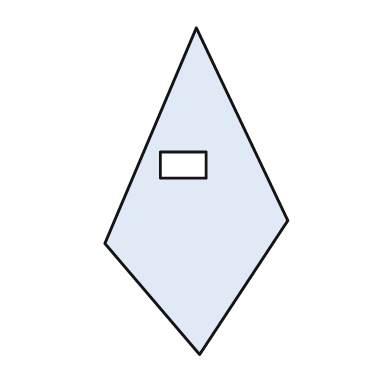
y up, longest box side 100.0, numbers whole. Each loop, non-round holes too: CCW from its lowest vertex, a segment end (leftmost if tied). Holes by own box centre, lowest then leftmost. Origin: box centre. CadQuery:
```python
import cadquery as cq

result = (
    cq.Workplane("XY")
    .moveTo(1.0, -50.0)
    .lineTo(28.0, -9.0)
    .lineTo(0.0, 50.0)
    .lineTo(-28.0, -16.0)
    .close()
    .moveTo(-11.0, 4.0)
    .lineTo(3.0, 4.0)
    .lineTo(3.0, 12.0)
    .lineTo(-11.0, 12.0)
    .close()
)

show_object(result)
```